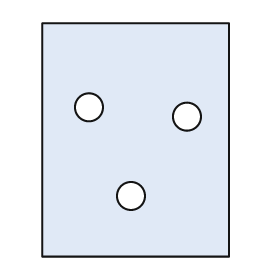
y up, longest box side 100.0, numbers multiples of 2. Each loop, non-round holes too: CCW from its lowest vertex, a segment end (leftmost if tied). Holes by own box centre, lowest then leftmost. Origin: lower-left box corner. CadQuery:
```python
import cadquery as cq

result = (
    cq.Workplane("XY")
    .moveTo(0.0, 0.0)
    .lineTo(80.0, 0.0)
    .lineTo(80.0, 100.0)
    .lineTo(0.0, 100.0)
    .close()
    .moveTo(38.0, 26.0)
    .circle(6.0)
    .moveTo(62.0, 60.0)
    .circle(6.0)
    .moveTo(20.0, 64.0)
    .circle(6.0)
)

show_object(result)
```